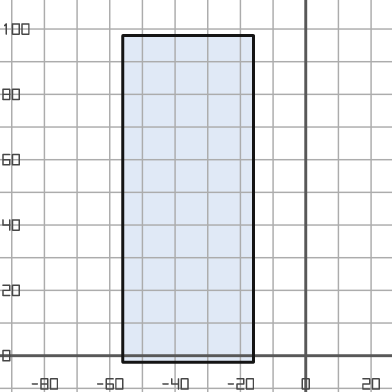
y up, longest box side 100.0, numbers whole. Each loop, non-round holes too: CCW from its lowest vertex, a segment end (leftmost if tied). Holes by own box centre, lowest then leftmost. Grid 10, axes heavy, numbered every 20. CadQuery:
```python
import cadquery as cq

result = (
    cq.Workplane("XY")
    .moveTo(-56.0, -2.0)
    .lineTo(-16.0, -2.0)
    .lineTo(-16.0, 98.0)
    .lineTo(-56.0, 98.0)
    .close()
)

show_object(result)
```